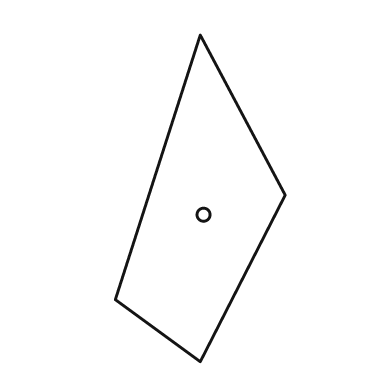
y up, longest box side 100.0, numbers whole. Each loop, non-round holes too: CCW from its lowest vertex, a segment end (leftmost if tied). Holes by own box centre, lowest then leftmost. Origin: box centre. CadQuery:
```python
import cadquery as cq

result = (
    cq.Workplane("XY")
    .moveTo(0.0, -50.0)
    .lineTo(26.0, 1.0)
    .lineTo(0.0, 50.0)
    .lineTo(-26.0, -31.0)
    .close()
    .moveTo(1.0, -5.0)
    .circle(2.0)
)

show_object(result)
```